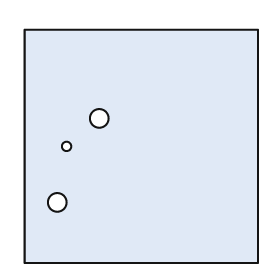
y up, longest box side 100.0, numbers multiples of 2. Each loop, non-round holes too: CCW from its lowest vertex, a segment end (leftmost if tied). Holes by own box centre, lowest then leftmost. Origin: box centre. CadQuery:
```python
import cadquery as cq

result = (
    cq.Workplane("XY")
    .moveTo(-50.0, -50.0)
    .lineTo(50.0, -50.0)
    .lineTo(50.0, 50.0)
    .lineTo(-50.0, 50.0)
    .close()
    .moveTo(-36.0, -24.0)
    .circle(4.0)
    .moveTo(-32.0, 0.0)
    .circle(2.0)
    .moveTo(-18.0, 12.0)
    .circle(4.0)
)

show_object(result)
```